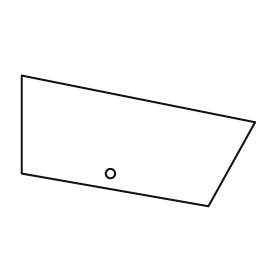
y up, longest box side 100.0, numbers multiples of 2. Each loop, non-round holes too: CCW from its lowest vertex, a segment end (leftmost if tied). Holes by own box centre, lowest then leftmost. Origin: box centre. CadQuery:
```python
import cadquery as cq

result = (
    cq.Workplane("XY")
    .moveTo(30.0, -28.0)
    .lineTo(50.0, 8.0)
    .lineTo(-50.0, 28.0)
    .lineTo(-50.0, -14.0)
    .close()
    .moveTo(-12.0, -14.0)
    .circle(2.0)
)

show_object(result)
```